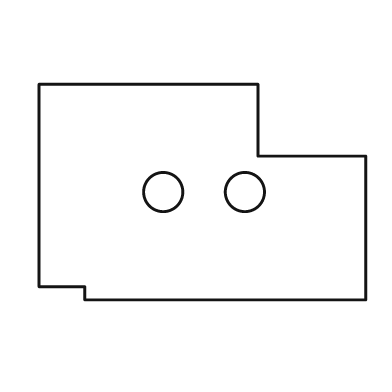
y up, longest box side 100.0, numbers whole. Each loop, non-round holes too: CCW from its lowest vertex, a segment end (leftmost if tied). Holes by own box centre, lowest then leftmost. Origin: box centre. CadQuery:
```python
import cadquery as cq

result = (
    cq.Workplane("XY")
    .moveTo(-36.0, -33.0)
    .lineTo(50.0, -33.0)
    .lineTo(50.0, 11.0)
    .lineTo(17.0, 11.0)
    .lineTo(17.0, 33.0)
    .lineTo(-50.0, 33.0)
    .lineTo(-50.0, -29.0)
    .lineTo(-36.0, -29.0)
    .close()
    .moveTo(-12.0, 0.0)
    .circle(6.0)
    .moveTo(13.0, 0.0)
    .circle(6.0)
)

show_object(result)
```